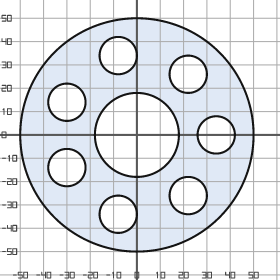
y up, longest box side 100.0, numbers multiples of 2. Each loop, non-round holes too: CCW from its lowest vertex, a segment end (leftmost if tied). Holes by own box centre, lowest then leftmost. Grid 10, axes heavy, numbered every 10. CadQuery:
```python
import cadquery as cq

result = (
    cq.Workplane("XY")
    .moveTo(0.0, 0.0)
    .circle(50.0)
    .moveTo(-8.0, -34.0)
    .circle(8.0)
    .moveTo(22.0, -26.0)
    .circle(8.0)
    .moveTo(-30.0, -14.0)
    .circle(8.0)
    .moveTo(0.0, 0.0)
    .circle(18.0)
    .moveTo(34.0, 0.0)
    .circle(8.0)
    .moveTo(-30.0, 14.0)
    .circle(8.0)
    .moveTo(22.0, 26.0)
    .circle(8.0)
    .moveTo(-8.0, 34.0)
    .circle(8.0)
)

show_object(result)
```